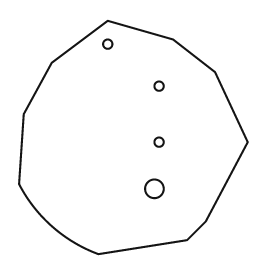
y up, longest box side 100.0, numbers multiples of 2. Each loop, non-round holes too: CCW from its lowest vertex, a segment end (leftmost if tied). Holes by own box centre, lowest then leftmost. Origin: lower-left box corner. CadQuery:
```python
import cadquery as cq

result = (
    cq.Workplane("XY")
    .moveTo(34.0, 0.0)
    .lineTo(72.0, 6.0)
    .lineTo(80.0, 14.0)
    .lineTo(98.0, 48.0)
    .lineTo(84.0, 78.0)
    .lineTo(66.0, 92.0)
    .lineTo(38.0, 100.0)
    .lineTo(14.0, 82.0)
    .lineTo(2.0, 60.0)
    .lineTo(0.0, 30.0)
    .threePointArc((14.0, 12.0), (34.0, 0.0))
    .close()
    .moveTo(58.0, 28.0)
    .circle(4.0)
    .moveTo(60.0, 48.0)
    .circle(2.0)
    .moveTo(60.0, 72.0)
    .circle(2.0)
    .moveTo(38.0, 90.0)
    .circle(2.0)
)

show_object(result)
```